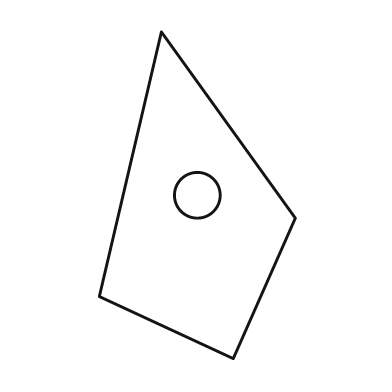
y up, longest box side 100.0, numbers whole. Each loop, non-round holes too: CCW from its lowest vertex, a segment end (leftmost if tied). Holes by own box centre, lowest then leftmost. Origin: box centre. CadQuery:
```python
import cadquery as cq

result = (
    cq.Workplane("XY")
    .moveTo(11.0, -50.0)
    .lineTo(30.0, -7.0)
    .lineTo(-11.0, 50.0)
    .lineTo(-30.0, -31.0)
    .close()
    .moveTo(0.0, 0.0)
    .circle(7.0)
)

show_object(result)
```